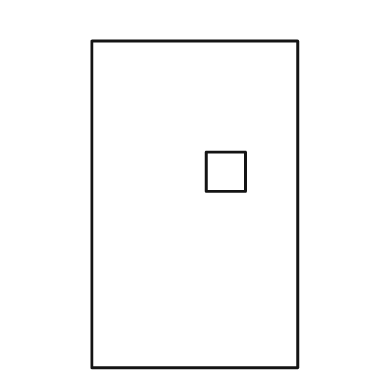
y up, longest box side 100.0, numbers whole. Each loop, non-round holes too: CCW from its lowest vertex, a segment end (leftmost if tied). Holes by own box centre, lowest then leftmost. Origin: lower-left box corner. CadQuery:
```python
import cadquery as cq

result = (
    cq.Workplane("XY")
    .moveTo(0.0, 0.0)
    .lineTo(63.0, 0.0)
    .lineTo(63.0, 100.0)
    .lineTo(0.0, 100.0)
    .close()
    .moveTo(35.0, 54.0)
    .lineTo(47.0, 54.0)
    .lineTo(47.0, 66.0)
    .lineTo(35.0, 66.0)
    .close()
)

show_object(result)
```